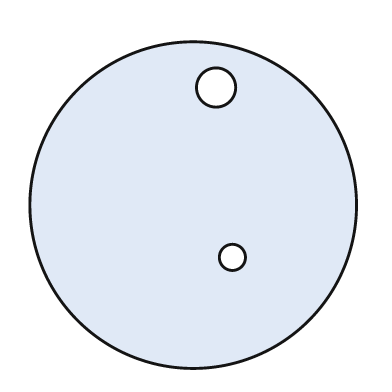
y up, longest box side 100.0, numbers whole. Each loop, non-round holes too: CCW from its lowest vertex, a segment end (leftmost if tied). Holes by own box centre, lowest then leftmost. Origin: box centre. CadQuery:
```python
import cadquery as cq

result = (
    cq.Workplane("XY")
    .moveTo(0.0, 0.0)
    .circle(50.0)
    .moveTo(12.0, -16.0)
    .circle(4.0)
    .moveTo(7.0, 36.0)
    .circle(6.0)
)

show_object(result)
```